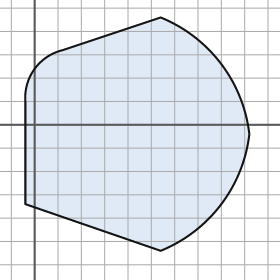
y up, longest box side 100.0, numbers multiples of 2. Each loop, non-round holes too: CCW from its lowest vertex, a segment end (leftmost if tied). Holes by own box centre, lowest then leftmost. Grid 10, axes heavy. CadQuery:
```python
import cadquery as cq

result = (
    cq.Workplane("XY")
    .moveTo(54.0, -54.0)
    .threePointArc((80.0, -34.0), (92.0, -4.0))
    .threePointArc((80.0, 26.0), (54.0, 46.0))
    .lineTo(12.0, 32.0)
    .threePointArc((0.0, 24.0), (-4.0, 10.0))
    .lineTo(-4.0, -34.0)
    .close()
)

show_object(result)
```